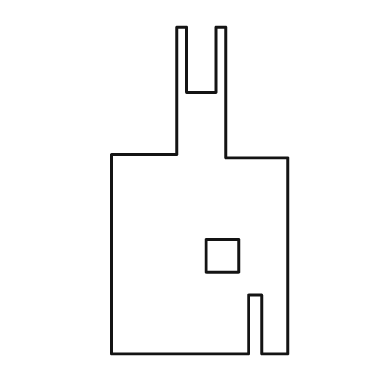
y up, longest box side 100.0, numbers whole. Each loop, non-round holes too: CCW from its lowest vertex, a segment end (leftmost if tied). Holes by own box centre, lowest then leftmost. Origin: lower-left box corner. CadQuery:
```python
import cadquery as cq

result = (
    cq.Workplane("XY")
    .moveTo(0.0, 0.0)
    .lineTo(42.0, 0.0)
    .lineTo(42.0, 18.0)
    .lineTo(46.0, 18.0)
    .lineTo(46.0, 0.0)
    .lineTo(54.0, 0.0)
    .lineTo(54.0, 60.0)
    .lineTo(35.0, 60.0)
    .lineTo(35.0, 100.0)
    .lineTo(32.0, 100.0)
    .lineTo(32.0, 80.0)
    .lineTo(23.0, 80.0)
    .lineTo(23.0, 100.0)
    .lineTo(20.0, 100.0)
    .lineTo(20.0, 61.0)
    .lineTo(0.0, 61.0)
    .close()
    .moveTo(29.0, 25.0)
    .lineTo(39.0, 25.0)
    .lineTo(39.0, 35.0)
    .lineTo(29.0, 35.0)
    .close()
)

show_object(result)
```